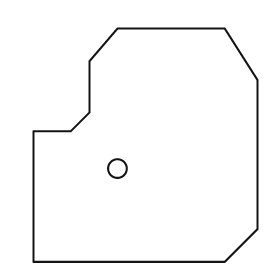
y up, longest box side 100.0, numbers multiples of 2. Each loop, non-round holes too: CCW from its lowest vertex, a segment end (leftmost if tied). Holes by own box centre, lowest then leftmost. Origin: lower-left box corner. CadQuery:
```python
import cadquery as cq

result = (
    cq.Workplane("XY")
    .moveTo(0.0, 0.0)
    .lineTo(82.0, 0.0)
    .lineTo(96.0, 14.0)
    .lineTo(96.0, 78.0)
    .lineTo(82.0, 100.0)
    .lineTo(36.0, 100.0)
    .lineTo(24.0, 86.0)
    .lineTo(24.0, 64.0)
    .lineTo(16.0, 56.0)
    .lineTo(0.0, 56.0)
    .close()
    .moveTo(36.0, 40.0)
    .circle(4.0)
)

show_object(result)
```